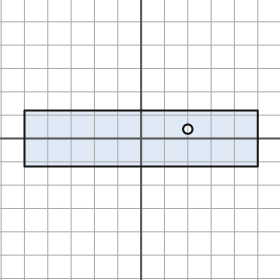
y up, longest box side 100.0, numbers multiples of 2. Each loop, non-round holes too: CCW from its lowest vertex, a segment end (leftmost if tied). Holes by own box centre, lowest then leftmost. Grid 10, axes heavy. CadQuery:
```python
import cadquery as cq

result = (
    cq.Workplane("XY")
    .moveTo(-50.0, -12.0)
    .lineTo(50.0, -12.0)
    .lineTo(50.0, 12.0)
    .lineTo(-50.0, 12.0)
    .close()
    .moveTo(20.0, 4.0)
    .circle(2.0)
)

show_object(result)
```